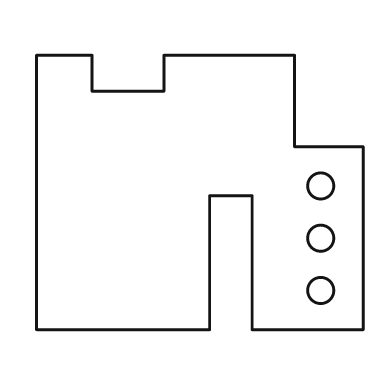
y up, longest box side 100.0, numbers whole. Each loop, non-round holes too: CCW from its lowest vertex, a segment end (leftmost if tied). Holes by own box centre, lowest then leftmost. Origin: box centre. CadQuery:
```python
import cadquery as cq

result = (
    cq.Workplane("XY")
    .moveTo(-50.0, -42.0)
    .lineTo(3.0, -42.0)
    .lineTo(3.0, -1.0)
    .lineTo(16.0, -1.0)
    .lineTo(16.0, -42.0)
    .lineTo(50.0, -42.0)
    .lineTo(50.0, 14.0)
    .lineTo(29.0, 14.0)
    .lineTo(29.0, 42.0)
    .lineTo(-11.0, 42.0)
    .lineTo(-11.0, 31.0)
    .lineTo(-33.0, 31.0)
    .lineTo(-33.0, 42.0)
    .lineTo(-50.0, 42.0)
    .close()
    .moveTo(37.0, -30.0)
    .circle(4.0)
    .moveTo(37.0, -14.0)
    .circle(4.0)
    .moveTo(37.0, 2.0)
    .circle(4.0)
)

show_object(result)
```